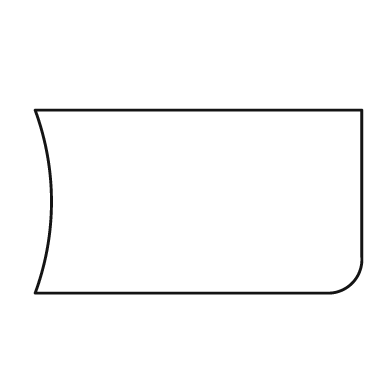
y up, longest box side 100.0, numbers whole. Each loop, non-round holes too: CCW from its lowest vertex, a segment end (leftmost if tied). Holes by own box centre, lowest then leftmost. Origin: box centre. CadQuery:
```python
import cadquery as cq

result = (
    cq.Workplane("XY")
    .moveTo(-50.0, -28.0)
    .lineTo(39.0, -28.0)
    .threePointArc((47.0, -25.0), (50.0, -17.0))
    .lineTo(50.0, 28.0)
    .lineTo(-50.0, 28.0)
    .threePointArc((-45.0, 0.0), (-50.0, -28.0))
    .close()
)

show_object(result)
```